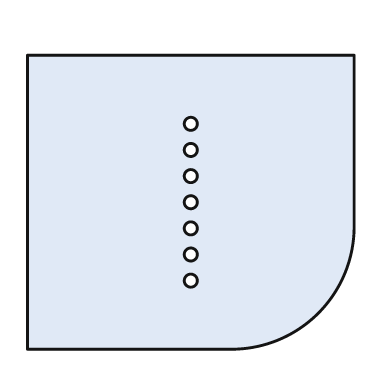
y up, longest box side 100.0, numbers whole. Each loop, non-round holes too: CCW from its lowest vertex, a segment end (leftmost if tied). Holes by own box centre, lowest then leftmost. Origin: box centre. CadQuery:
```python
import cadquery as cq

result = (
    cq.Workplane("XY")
    .moveTo(-50.0, -45.0)
    .lineTo(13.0, -45.0)
    .threePointArc((39.0, -34.0), (50.0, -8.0))
    .lineTo(50.0, 45.0)
    .lineTo(-50.0, 45.0)
    .close()
    .moveTo(0.0, -24.0)
    .circle(2.0)
    .moveTo(0.0, -16.0)
    .circle(2.0)
    .moveTo(0.0, -8.0)
    .circle(2.0)
    .moveTo(0.0, 0.0)
    .circle(2.0)
    .moveTo(0.0, 8.0)
    .circle(2.0)
    .moveTo(0.0, 16.0)
    .circle(2.0)
    .moveTo(0.0, 24.0)
    .circle(2.0)
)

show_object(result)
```